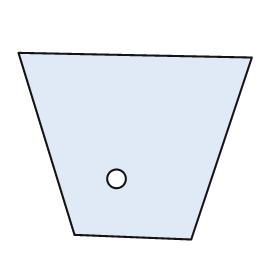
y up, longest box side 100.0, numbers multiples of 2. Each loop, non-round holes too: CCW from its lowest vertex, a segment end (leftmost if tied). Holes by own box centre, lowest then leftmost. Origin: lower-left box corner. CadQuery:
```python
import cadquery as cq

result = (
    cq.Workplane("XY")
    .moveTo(74.0, 0.0)
    .lineTo(100.0, 78.0)
    .lineTo(0.0, 80.0)
    .lineTo(24.0, 2.0)
    .close()
    .moveTo(42.0, 26.0)
    .circle(4.0)
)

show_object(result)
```